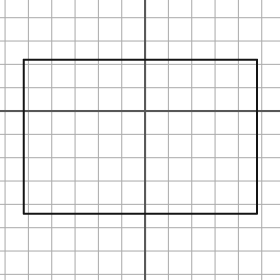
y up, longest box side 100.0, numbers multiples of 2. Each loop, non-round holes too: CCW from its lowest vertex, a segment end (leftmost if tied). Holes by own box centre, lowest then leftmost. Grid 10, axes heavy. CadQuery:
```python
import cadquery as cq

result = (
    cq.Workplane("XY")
    .moveTo(-52.0, -44.0)
    .lineTo(48.0, -44.0)
    .lineTo(48.0, 22.0)
    .lineTo(-52.0, 22.0)
    .close()
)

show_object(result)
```